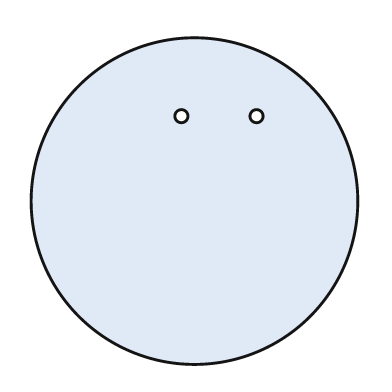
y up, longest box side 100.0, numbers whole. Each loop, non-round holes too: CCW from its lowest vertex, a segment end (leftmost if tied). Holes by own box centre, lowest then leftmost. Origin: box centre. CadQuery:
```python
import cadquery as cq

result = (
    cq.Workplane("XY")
    .moveTo(0.0, 0.0)
    .circle(50.0)
    .moveTo(-4.0, 26.0)
    .circle(2.0)
    .moveTo(19.0, 26.0)
    .circle(2.0)
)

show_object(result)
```